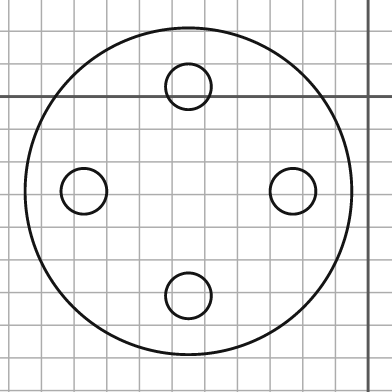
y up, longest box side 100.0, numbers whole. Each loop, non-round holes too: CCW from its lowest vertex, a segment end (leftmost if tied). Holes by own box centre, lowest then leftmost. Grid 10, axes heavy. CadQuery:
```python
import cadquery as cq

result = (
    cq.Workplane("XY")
    .moveTo(-55.0, -29.0)
    .circle(50.0)
    .moveTo(-55.0, -61.0)
    .circle(7.0)
    .moveTo(-87.0, -29.0)
    .circle(7.0)
    .moveTo(-23.0, -29.0)
    .circle(7.0)
    .moveTo(-55.0, 3.0)
    .circle(7.0)
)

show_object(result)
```